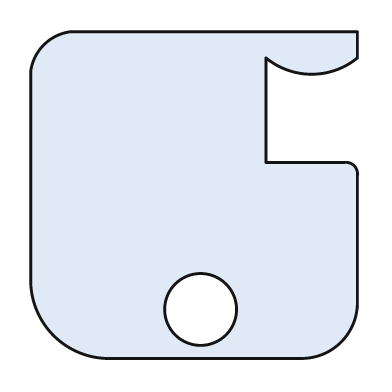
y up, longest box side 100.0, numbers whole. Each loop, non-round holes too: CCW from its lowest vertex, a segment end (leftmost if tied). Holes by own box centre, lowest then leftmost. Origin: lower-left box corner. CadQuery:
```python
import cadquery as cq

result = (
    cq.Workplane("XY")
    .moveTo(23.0, 0.0)
    .lineTo(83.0, 0.0)
    .threePointArc((95.0, 5.0), (100.0, 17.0))
    .lineTo(100.0, 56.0)
    .threePointArc((99.0, 59.0), (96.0, 60.0))
    .lineTo(72.0, 60.0)
    .lineTo(72.0, 92.0)
    .threePointArc((86.0, 87.0), (100.0, 92.0))
    .lineTo(100.0, 100.0)
    .lineTo(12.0, 100.0)
    .threePointArc((4.0, 96.0), (0.0, 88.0))
    .lineTo(0.0, 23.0)
    .threePointArc((7.0, 7.0), (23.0, 0.0))
    .close()
    .moveTo(52.0, 15.0)
    .circle(11.0)
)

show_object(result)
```